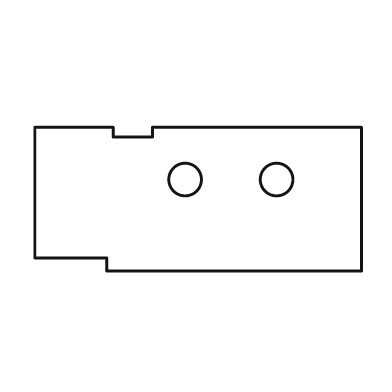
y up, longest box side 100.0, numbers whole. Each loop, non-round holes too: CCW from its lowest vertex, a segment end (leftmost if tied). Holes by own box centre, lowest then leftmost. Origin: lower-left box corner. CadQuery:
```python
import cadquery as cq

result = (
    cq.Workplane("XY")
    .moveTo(22.0, 0.0)
    .lineTo(100.0, 0.0)
    .lineTo(100.0, 44.0)
    .lineTo(36.0, 44.0)
    .lineTo(36.0, 41.0)
    .lineTo(24.0, 41.0)
    .lineTo(24.0, 44.0)
    .lineTo(0.0, 44.0)
    .lineTo(0.0, 4.0)
    .lineTo(22.0, 4.0)
    .close()
    .moveTo(46.0, 28.0)
    .circle(5.0)
    .moveTo(74.0, 28.0)
    .circle(5.0)
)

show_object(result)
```